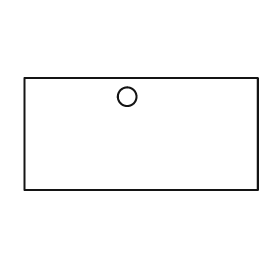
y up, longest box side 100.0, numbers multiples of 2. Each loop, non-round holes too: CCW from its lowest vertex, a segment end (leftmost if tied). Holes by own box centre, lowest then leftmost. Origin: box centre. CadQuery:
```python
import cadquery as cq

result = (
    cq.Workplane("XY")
    .moveTo(-50.0, -24.0)
    .lineTo(50.0, -24.0)
    .lineTo(50.0, 24.0)
    .lineTo(-50.0, 24.0)
    .close()
    .moveTo(-6.0, 16.0)
    .circle(4.0)
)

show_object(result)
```